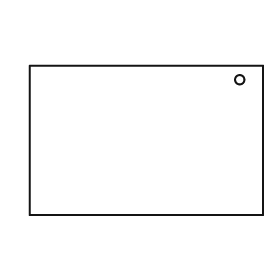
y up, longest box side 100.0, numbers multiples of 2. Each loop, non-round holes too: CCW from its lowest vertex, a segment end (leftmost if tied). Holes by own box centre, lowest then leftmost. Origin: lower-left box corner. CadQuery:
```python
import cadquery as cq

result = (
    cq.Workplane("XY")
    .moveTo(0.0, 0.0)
    .lineTo(100.0, 0.0)
    .lineTo(100.0, 64.0)
    .lineTo(0.0, 64.0)
    .close()
    .moveTo(90.0, 58.0)
    .circle(2.0)
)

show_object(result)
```